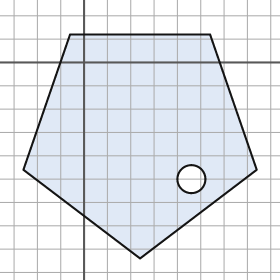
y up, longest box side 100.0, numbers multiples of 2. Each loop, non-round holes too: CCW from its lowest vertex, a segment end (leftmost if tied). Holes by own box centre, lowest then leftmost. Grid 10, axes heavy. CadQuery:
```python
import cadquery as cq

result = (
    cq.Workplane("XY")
    .moveTo(24.0, -84.0)
    .lineTo(74.0, -46.0)
    .lineTo(54.0, 12.0)
    .lineTo(-6.0, 12.0)
    .lineTo(-26.0, -46.0)
    .close()
    .moveTo(46.0, -50.0)
    .circle(6.0)
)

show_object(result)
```